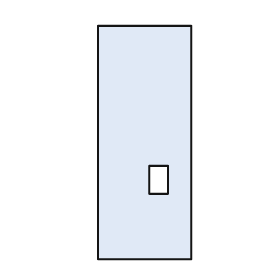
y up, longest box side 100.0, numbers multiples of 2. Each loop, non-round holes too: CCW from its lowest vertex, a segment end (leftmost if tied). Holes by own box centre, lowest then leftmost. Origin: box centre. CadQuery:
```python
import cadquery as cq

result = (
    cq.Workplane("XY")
    .moveTo(-20.0, -50.0)
    .lineTo(20.0, -50.0)
    .lineTo(20.0, 50.0)
    .lineTo(-20.0, 50.0)
    .close()
    .moveTo(2.0, -22.0)
    .lineTo(10.0, -22.0)
    .lineTo(10.0, -10.0)
    .lineTo(2.0, -10.0)
    .close()
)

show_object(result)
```